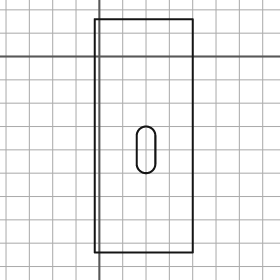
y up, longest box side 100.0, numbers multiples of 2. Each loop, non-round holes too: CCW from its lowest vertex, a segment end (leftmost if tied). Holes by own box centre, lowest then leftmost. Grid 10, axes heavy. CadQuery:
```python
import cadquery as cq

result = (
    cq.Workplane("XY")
    .moveTo(-2.0, -84.0)
    .lineTo(40.0, -84.0)
    .lineTo(40.0, 16.0)
    .lineTo(-2.0, 16.0)
    .close()
    .moveTo(16.0, -46.0)
    .threePointArc((20.0, -50.0), (24.0, -46.0))
    .lineTo(24.0, -34.0)
    .threePointArc((20.0, -30.0), (16.0, -34.0))
    .close()
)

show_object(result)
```